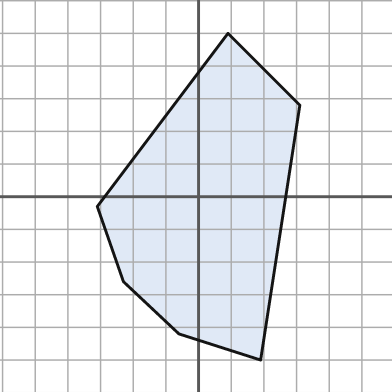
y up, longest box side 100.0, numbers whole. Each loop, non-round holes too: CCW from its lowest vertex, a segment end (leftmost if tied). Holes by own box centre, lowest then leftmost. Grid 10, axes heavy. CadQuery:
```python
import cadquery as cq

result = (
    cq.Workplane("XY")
    .moveTo(19.0, -50.0)
    .lineTo(31.0, 28.0)
    .lineTo(9.0, 50.0)
    .lineTo(-31.0, -3.0)
    .lineTo(-23.0, -26.0)
    .lineTo(-6.0, -42.0)
    .close()
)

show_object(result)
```